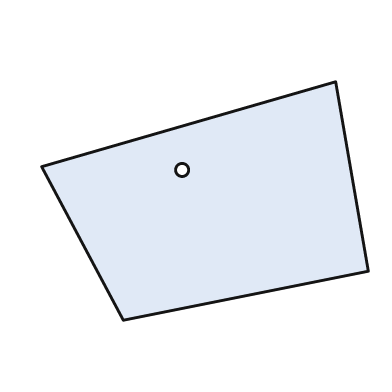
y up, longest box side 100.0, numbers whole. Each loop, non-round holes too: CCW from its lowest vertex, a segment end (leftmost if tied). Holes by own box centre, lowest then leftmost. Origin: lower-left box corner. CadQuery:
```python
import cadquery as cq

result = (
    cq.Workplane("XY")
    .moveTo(25.0, 0.0)
    .lineTo(100.0, 15.0)
    .lineTo(90.0, 73.0)
    .lineTo(0.0, 47.0)
    .close()
    .moveTo(43.0, 46.0)
    .circle(2.0)
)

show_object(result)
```